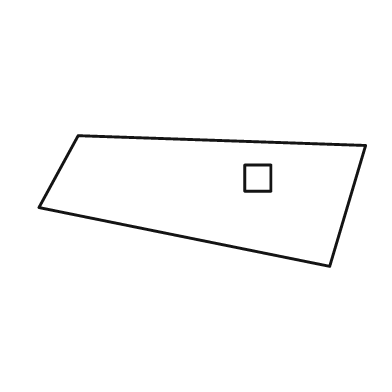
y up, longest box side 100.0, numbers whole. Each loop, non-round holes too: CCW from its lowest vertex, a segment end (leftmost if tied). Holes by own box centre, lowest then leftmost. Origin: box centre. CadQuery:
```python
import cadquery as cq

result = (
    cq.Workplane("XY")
    .moveTo(39.0, -20.0)
    .lineTo(50.0, 17.0)
    .lineTo(-38.0, 20.0)
    .lineTo(-50.0, -2.0)
    .close()
    .moveTo(13.0, 3.0)
    .lineTo(21.0, 3.0)
    .lineTo(21.0, 11.0)
    .lineTo(13.0, 11.0)
    .close()
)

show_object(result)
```